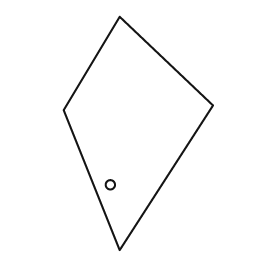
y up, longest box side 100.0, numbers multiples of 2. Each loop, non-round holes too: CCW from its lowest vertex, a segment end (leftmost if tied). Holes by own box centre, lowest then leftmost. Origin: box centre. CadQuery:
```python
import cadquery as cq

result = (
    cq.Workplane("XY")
    .moveTo(-8.0, -50.0)
    .lineTo(32.0, 12.0)
    .lineTo(-8.0, 50.0)
    .lineTo(-32.0, 10.0)
    .close()
    .moveTo(-12.0, -22.0)
    .circle(2.0)
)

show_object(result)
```